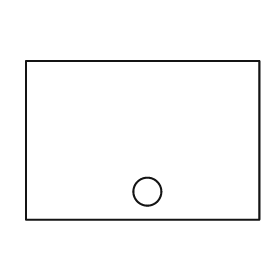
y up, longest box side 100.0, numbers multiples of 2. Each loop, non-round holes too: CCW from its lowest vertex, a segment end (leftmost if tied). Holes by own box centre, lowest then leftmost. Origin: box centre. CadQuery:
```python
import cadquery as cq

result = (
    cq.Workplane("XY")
    .moveTo(-50.0, -34.0)
    .lineTo(50.0, -34.0)
    .lineTo(50.0, 34.0)
    .lineTo(-50.0, 34.0)
    .close()
    .moveTo(2.0, -22.0)
    .circle(6.0)
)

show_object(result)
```